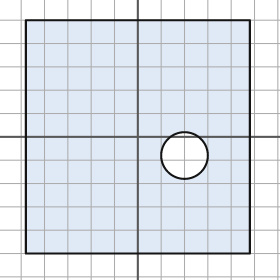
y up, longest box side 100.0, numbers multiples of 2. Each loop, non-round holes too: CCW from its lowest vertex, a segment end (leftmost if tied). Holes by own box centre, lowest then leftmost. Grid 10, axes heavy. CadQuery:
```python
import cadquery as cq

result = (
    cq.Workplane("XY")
    .moveTo(-48.0, -50.0)
    .lineTo(48.0, -50.0)
    .lineTo(48.0, 50.0)
    .lineTo(-48.0, 50.0)
    .close()
    .moveTo(20.0, -8.0)
    .circle(10.0)
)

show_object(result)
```